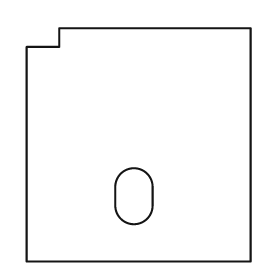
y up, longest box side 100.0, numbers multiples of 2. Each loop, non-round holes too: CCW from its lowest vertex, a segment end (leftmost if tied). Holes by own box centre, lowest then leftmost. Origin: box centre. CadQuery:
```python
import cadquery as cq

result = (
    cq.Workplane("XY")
    .moveTo(-48.0, -50.0)
    .lineTo(48.0, -50.0)
    .lineTo(48.0, 50.0)
    .lineTo(-34.0, 50.0)
    .lineTo(-34.0, 42.0)
    .lineTo(-48.0, 42.0)
    .close()
    .moveTo(-10.0, -26.0)
    .threePointArc((-2.0, -34.0), (6.0, -26.0))
    .lineTo(6.0, -18.0)
    .threePointArc((-2.0, -10.0), (-10.0, -18.0))
    .close()
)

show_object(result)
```